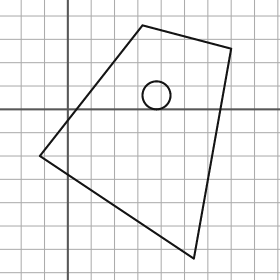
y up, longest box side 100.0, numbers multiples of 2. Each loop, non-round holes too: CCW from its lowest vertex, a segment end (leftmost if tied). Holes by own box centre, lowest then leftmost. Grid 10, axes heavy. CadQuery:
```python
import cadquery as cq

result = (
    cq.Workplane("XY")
    .moveTo(54.0, -64.0)
    .lineTo(70.0, 26.0)
    .lineTo(32.0, 36.0)
    .lineTo(-12.0, -20.0)
    .close()
    .moveTo(38.0, 6.0)
    .circle(6.0)
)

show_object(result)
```